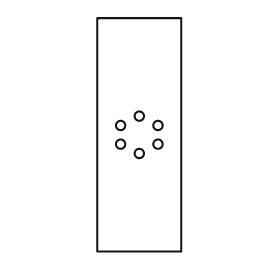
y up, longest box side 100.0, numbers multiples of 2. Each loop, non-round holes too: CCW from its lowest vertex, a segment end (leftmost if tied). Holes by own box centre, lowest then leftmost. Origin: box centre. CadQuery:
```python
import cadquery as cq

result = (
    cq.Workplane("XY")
    .moveTo(-18.0, -50.0)
    .lineTo(18.0, -50.0)
    .lineTo(18.0, 50.0)
    .lineTo(-18.0, 50.0)
    .close()
    .moveTo(0.0, -8.0)
    .circle(2.0)
    .moveTo(-8.0, -4.0)
    .circle(2.0)
    .moveTo(8.0, -4.0)
    .circle(2.0)
    .moveTo(-8.0, 4.0)
    .circle(2.0)
    .moveTo(8.0, 4.0)
    .circle(2.0)
    .moveTo(0.0, 8.0)
    .circle(2.0)
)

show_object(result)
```